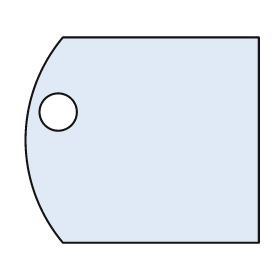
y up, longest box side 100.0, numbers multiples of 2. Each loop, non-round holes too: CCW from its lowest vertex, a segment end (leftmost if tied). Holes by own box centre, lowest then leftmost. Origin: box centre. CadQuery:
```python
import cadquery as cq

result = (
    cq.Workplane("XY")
    .moveTo(-34.0, -44.0)
    .lineTo(50.0, -44.0)
    .lineTo(50.0, 44.0)
    .lineTo(-34.0, 44.0)
    .threePointArc((-50.0, 0.0), (-34.0, -44.0))
    .close()
    .moveTo(-36.0, 12.0)
    .circle(8.0)
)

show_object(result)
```